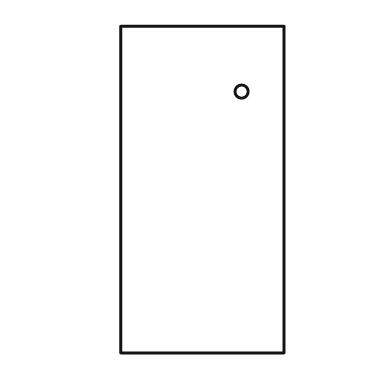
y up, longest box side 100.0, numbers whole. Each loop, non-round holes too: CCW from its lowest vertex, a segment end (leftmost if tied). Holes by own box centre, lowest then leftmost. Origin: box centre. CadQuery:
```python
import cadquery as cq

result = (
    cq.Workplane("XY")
    .moveTo(-25.0, -50.0)
    .lineTo(25.0, -50.0)
    .lineTo(25.0, 50.0)
    .lineTo(-25.0, 50.0)
    .close()
    .moveTo(12.0, 30.0)
    .circle(2.0)
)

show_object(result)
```